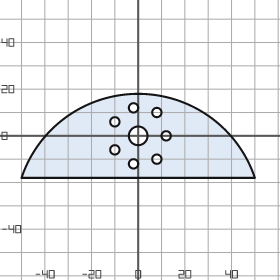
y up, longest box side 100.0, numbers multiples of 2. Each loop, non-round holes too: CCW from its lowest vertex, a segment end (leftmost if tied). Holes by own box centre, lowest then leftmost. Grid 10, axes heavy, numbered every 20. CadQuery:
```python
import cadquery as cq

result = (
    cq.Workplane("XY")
    .moveTo(-50.0, -18.0)
    .lineTo(50.0, -18.0)
    .threePointArc((0.0, 18.0), (-50.0, -18.0))
    .close()
    .moveTo(-2.0, -12.0)
    .circle(2.0)
    .moveTo(8.0, -10.0)
    .circle(2.0)
    .moveTo(-10.0, -6.0)
    .circle(2.0)
    .moveTo(0.0, 0.0)
    .circle(4.0)
    .moveTo(12.0, 0.0)
    .circle(2.0)
    .moveTo(-10.0, 6.0)
    .circle(2.0)
    .moveTo(8.0, 10.0)
    .circle(2.0)
    .moveTo(-2.0, 12.0)
    .circle(2.0)
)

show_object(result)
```